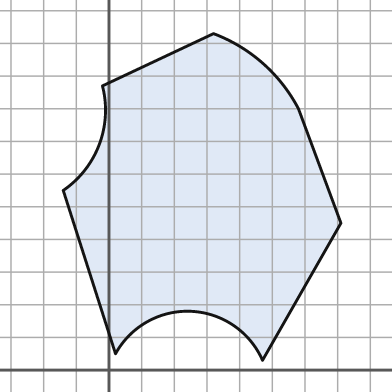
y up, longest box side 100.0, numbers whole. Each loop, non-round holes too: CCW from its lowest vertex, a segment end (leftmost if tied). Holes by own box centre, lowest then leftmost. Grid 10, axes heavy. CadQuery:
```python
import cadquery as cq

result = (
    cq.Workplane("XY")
    .moveTo(47.0, 3.0)
    .lineTo(71.0, 45.0)
    .lineTo(58.0, 80.0)
    .threePointArc((47.0, 94.0), (32.0, 103.0))
    .lineTo(-2.0, 87.0)
    .threePointArc((-3.0, 69.0), (-14.0, 55.0))
    .lineTo(2.0, 5.0)
    .threePointArc((25.0, 18.0), (47.0, 3.0))
    .close()
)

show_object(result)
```